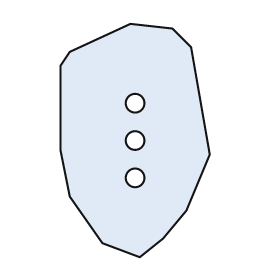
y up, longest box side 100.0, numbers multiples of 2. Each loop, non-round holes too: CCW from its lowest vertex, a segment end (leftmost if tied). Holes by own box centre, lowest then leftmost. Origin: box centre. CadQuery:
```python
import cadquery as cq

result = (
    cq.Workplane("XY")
    .moveTo(2.0, -50.0)
    .lineTo(12.0, -42.0)
    .lineTo(22.0, -30.0)
    .lineTo(32.0, -6.0)
    .lineTo(24.0, 40.0)
    .lineTo(16.0, 48.0)
    .lineTo(-2.0, 50.0)
    .lineTo(-28.0, 38.0)
    .lineTo(-32.0, 32.0)
    .lineTo(-32.0, -4.0)
    .lineTo(-28.0, -24.0)
    .lineTo(-14.0, -44.0)
    .close()
    .moveTo(0.0, -16.0)
    .circle(4.0)
    .moveTo(0.0, 0.0)
    .circle(4.0)
    .moveTo(0.0, 16.0)
    .circle(4.0)
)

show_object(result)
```